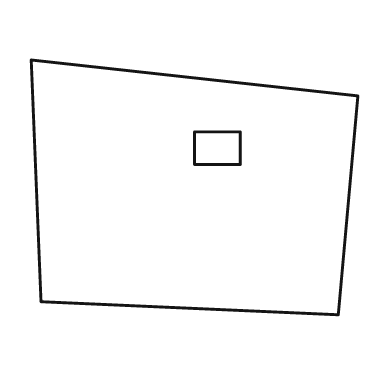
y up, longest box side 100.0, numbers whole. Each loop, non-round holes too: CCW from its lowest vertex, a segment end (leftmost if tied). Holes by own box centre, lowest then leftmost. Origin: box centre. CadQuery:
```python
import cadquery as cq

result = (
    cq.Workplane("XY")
    .moveTo(44.0, -39.0)
    .lineTo(50.0, 28.0)
    .lineTo(-50.0, 39.0)
    .lineTo(-47.0, -35.0)
    .close()
    .moveTo(0.0, 7.0)
    .lineTo(14.0, 7.0)
    .lineTo(14.0, 17.0)
    .lineTo(0.0, 17.0)
    .close()
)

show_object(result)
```